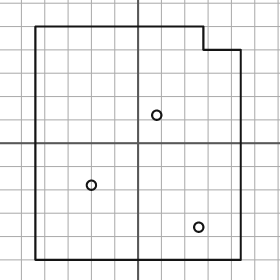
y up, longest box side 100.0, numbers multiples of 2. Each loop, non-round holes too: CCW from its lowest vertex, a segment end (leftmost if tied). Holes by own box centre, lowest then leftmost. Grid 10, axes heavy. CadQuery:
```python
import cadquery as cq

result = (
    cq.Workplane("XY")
    .moveTo(-44.0, -50.0)
    .lineTo(44.0, -50.0)
    .lineTo(44.0, 40.0)
    .lineTo(28.0, 40.0)
    .lineTo(28.0, 50.0)
    .lineTo(-44.0, 50.0)
    .close()
    .moveTo(26.0, -36.0)
    .circle(2.0)
    .moveTo(-20.0, -18.0)
    .circle(2.0)
    .moveTo(8.0, 12.0)
    .circle(2.0)
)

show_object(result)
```